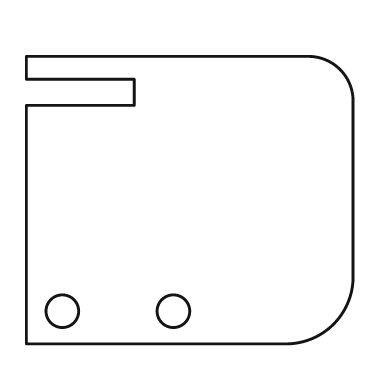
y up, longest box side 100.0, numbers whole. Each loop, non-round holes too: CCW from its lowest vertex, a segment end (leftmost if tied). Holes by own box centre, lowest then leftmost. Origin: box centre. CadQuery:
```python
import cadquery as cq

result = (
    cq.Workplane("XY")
    .moveTo(-50.0, -44.0)
    .lineTo(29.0, -44.0)
    .threePointArc((44.0, -38.0), (50.0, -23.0))
    .lineTo(50.0, 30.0)
    .threePointArc((46.0, 40.0), (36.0, 44.0))
    .lineTo(-50.0, 44.0)
    .lineTo(-50.0, 37.0)
    .lineTo(-17.0, 37.0)
    .lineTo(-17.0, 29.0)
    .lineTo(-50.0, 29.0)
    .close()
    .moveTo(-39.0, -34.0)
    .circle(5.0)
    .moveTo(-5.0, -34.0)
    .circle(5.0)
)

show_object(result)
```